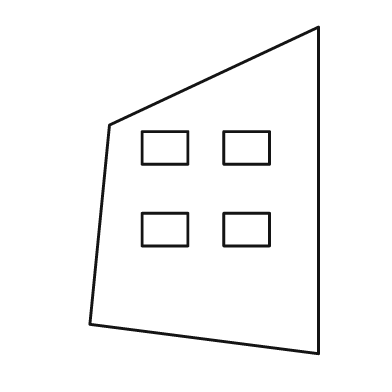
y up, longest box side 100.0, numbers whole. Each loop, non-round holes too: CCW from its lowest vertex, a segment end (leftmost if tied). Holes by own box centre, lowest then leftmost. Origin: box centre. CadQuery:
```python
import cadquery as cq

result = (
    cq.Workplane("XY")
    .moveTo(35.0, -50.0)
    .lineTo(35.0, 50.0)
    .lineTo(-29.0, 20.0)
    .lineTo(-35.0, -41.0)
    .close()
    .moveTo(-19.0, -17.0)
    .lineTo(-5.0, -17.0)
    .lineTo(-5.0, -7.0)
    .lineTo(-19.0, -7.0)
    .close()
    .moveTo(6.0, -17.0)
    .lineTo(20.0, -17.0)
    .lineTo(20.0, -7.0)
    .lineTo(6.0, -7.0)
    .close()
    .moveTo(-19.0, 8.0)
    .lineTo(-5.0, 8.0)
    .lineTo(-5.0, 18.0)
    .lineTo(-19.0, 18.0)
    .close()
    .moveTo(6.0, 8.0)
    .lineTo(20.0, 8.0)
    .lineTo(20.0, 18.0)
    .lineTo(6.0, 18.0)
    .close()
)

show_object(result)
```